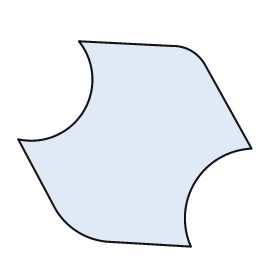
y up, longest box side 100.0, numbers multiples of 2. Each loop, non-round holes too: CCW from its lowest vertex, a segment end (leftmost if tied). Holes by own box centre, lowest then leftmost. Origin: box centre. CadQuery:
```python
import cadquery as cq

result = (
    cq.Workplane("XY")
    .moveTo(24.0, -44.0)
    .threePointArc((26.0, -16.0), (50.0, -2.0))
    .lineTo(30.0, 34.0)
    .threePointArc((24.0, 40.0), (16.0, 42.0))
    .lineTo(-24.0, 44.0)
    .threePointArc((-22.0, 14.0), (-50.0, 2.0))
    .lineTo(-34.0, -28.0)
    .threePointArc((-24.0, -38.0), (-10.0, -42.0))
    .close()
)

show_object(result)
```